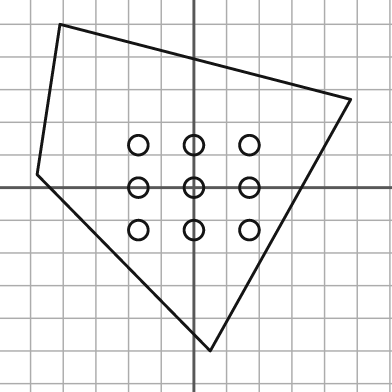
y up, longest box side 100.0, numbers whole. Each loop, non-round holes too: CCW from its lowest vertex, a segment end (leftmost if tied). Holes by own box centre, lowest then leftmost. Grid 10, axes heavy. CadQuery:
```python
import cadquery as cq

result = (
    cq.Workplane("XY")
    .moveTo(5.0, -50.0)
    .lineTo(48.0, 27.0)
    .lineTo(-41.0, 50.0)
    .lineTo(-48.0, 4.0)
    .close()
    .moveTo(-17.0, -13.0)
    .circle(3.0)
    .moveTo(0.0, -13.0)
    .circle(3.0)
    .moveTo(17.0, -13.0)
    .circle(3.0)
    .moveTo(-17.0, 0.0)
    .circle(3.0)
    .moveTo(0.0, 0.0)
    .circle(3.0)
    .moveTo(17.0, 0.0)
    .circle(3.0)
    .moveTo(-17.0, 13.0)
    .circle(3.0)
    .moveTo(0.0, 13.0)
    .circle(3.0)
    .moveTo(17.0, 13.0)
    .circle(3.0)
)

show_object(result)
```